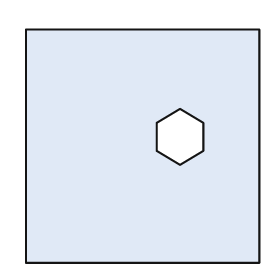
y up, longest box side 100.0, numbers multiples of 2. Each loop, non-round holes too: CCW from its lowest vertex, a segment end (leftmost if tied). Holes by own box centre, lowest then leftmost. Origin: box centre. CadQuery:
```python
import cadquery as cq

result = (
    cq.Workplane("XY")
    .moveTo(-50.0, -50.0)
    .lineTo(50.0, -50.0)
    .lineTo(50.0, 50.0)
    .lineTo(-50.0, 50.0)
    .close()
    .moveTo(16.0, -8.0)
    .lineTo(26.0, -2.0)
    .lineTo(26.0, 10.0)
    .lineTo(16.0, 16.0)
    .lineTo(6.0, 10.0)
    .lineTo(6.0, -2.0)
    .close()
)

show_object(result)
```